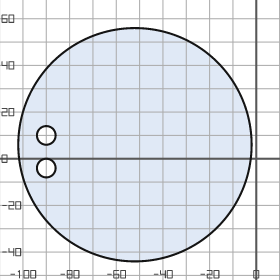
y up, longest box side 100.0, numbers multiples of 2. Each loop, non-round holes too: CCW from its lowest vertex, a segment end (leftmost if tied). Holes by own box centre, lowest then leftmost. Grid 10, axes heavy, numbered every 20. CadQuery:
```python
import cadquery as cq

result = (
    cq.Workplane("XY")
    .moveTo(-52.0, 6.0)
    .circle(50.0)
    .moveTo(-90.0, -4.0)
    .circle(4.0)
    .moveTo(-90.0, 10.0)
    .circle(4.0)
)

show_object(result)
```